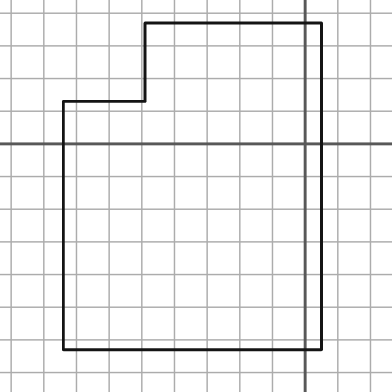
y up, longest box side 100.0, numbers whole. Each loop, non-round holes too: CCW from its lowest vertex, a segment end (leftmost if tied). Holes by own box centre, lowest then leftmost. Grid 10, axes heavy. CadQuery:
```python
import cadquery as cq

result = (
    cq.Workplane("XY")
    .moveTo(-74.0, -63.0)
    .lineTo(5.0, -63.0)
    .lineTo(5.0, 37.0)
    .lineTo(-49.0, 37.0)
    .lineTo(-49.0, 13.0)
    .lineTo(-74.0, 13.0)
    .close()
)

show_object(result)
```